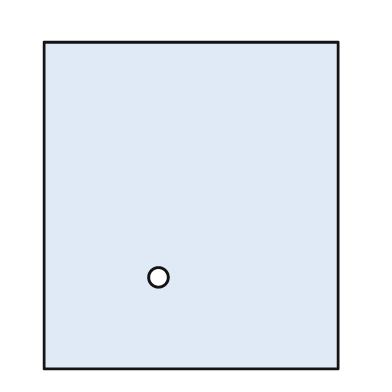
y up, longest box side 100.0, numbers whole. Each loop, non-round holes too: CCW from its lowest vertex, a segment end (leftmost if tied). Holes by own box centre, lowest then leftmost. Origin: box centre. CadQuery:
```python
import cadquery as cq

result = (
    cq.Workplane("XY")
    .moveTo(-45.0, -50.0)
    .lineTo(45.0, -50.0)
    .lineTo(45.0, 50.0)
    .lineTo(-45.0, 50.0)
    .close()
    .moveTo(-10.0, -22.0)
    .circle(3.0)
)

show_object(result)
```